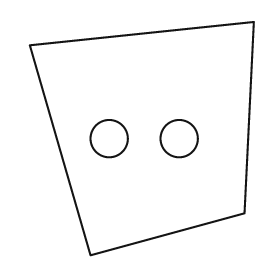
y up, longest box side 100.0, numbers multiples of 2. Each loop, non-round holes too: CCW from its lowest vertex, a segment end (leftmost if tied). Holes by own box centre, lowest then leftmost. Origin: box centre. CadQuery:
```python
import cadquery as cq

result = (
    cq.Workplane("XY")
    .moveTo(-22.0, -50.0)
    .lineTo(44.0, -32.0)
    .lineTo(48.0, 50.0)
    .lineTo(-48.0, 40.0)
    .close()
    .moveTo(-14.0, 0.0)
    .circle(8.0)
    .moveTo(16.0, 0.0)
    .circle(8.0)
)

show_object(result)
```